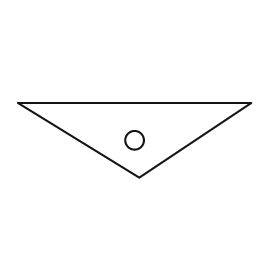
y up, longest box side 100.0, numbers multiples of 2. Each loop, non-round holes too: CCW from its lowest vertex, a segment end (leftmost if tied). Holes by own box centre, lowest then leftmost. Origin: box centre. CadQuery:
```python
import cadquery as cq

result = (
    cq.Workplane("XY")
    .moveTo(2.0, -16.0)
    .lineTo(50.0, 16.0)
    .lineTo(-50.0, 16.0)
    .close()
    .moveTo(0.0, 0.0)
    .circle(4.0)
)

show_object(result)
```